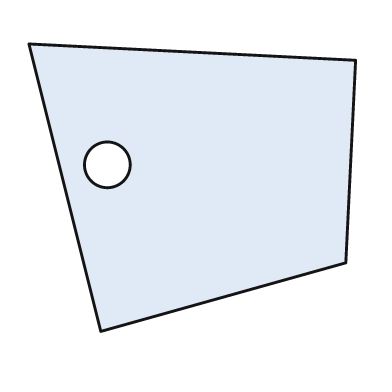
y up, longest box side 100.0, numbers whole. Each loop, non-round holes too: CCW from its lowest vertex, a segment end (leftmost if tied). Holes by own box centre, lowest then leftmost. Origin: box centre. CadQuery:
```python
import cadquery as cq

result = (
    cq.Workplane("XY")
    .moveTo(-28.0, -44.0)
    .lineTo(47.0, -23.0)
    .lineTo(50.0, 39.0)
    .lineTo(-50.0, 44.0)
    .close()
    .moveTo(-26.0, 7.0)
    .circle(7.0)
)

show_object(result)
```